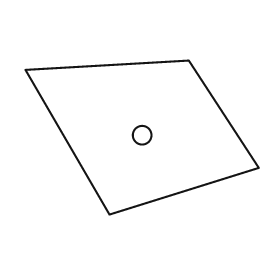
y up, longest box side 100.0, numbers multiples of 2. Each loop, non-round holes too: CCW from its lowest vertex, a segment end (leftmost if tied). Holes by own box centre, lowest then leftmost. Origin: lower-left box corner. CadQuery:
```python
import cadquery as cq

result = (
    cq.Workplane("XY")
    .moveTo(36.0, 0.0)
    .lineTo(100.0, 20.0)
    .lineTo(70.0, 66.0)
    .lineTo(0.0, 62.0)
    .close()
    .moveTo(50.0, 34.0)
    .circle(4.0)
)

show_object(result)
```